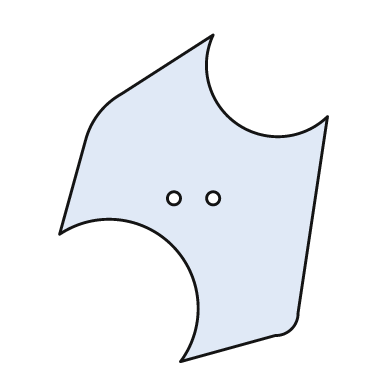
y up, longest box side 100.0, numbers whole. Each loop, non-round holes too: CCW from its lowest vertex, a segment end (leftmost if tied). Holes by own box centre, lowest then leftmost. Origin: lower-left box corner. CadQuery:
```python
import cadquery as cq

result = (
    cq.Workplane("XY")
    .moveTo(37.0, 0.0)
    .lineTo(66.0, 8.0)
    .threePointArc((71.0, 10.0), (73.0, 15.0))
    .lineTo(82.0, 75.0)
    .threePointArc((54.0, 73.0), (47.0, 100.0))
    .lineTo(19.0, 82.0)
    .threePointArc((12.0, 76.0), (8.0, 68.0))
    .lineTo(0.0, 39.0)
    .threePointArc((35.0, 35.0), (37.0, 0.0))
    .close()
    .moveTo(35.0, 50.0)
    .circle(2.0)
    .moveTo(47.0, 50.0)
    .circle(2.0)
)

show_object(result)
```